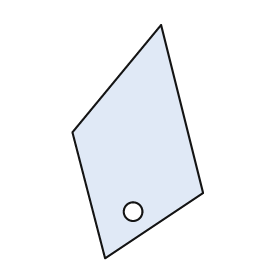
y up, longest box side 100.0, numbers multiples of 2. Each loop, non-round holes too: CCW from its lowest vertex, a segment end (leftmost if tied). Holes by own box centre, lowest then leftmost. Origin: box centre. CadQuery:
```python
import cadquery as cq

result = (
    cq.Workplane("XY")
    .moveTo(-14.0, -50.0)
    .lineTo(28.0, -22.0)
    .lineTo(10.0, 50.0)
    .lineTo(-28.0, 4.0)
    .close()
    .moveTo(-2.0, -30.0)
    .circle(4.0)
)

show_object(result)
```